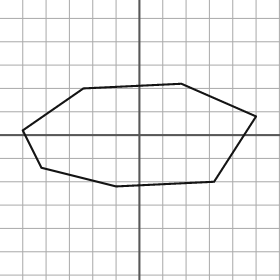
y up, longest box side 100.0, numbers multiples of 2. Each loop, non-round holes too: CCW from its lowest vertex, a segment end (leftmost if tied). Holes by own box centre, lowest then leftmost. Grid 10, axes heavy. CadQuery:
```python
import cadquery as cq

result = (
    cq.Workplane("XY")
    .moveTo(-10.0, -22.0)
    .lineTo(32.0, -20.0)
    .lineTo(50.0, 8.0)
    .lineTo(18.0, 22.0)
    .lineTo(-24.0, 20.0)
    .lineTo(-50.0, 2.0)
    .lineTo(-42.0, -14.0)
    .close()
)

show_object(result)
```